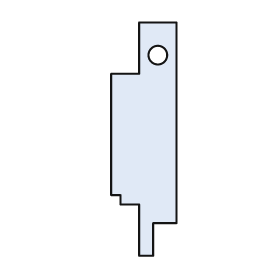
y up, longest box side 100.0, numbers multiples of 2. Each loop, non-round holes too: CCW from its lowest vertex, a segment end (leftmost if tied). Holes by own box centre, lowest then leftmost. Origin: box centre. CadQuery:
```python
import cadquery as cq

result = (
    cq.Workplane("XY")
    .moveTo(-2.0, -50.0)
    .lineTo(4.0, -50.0)
    .lineTo(4.0, -36.0)
    .lineTo(14.0, -36.0)
    .lineTo(14.0, 50.0)
    .lineTo(-2.0, 50.0)
    .lineTo(-2.0, 28.0)
    .lineTo(-14.0, 28.0)
    .lineTo(-14.0, -24.0)
    .lineTo(-10.0, -24.0)
    .lineTo(-10.0, -28.0)
    .lineTo(-2.0, -28.0)
    .close()
    .moveTo(6.0, 36.0)
    .circle(4.0)
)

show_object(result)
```